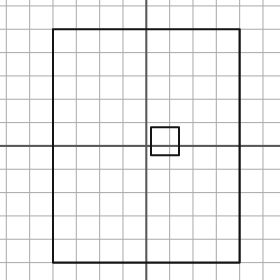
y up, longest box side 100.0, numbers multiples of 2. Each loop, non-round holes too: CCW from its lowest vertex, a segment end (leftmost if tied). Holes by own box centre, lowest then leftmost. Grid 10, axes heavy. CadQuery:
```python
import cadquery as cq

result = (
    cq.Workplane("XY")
    .moveTo(-40.0, -50.0)
    .lineTo(40.0, -50.0)
    .lineTo(40.0, 50.0)
    .lineTo(-40.0, 50.0)
    .close()
    .moveTo(2.0, -4.0)
    .lineTo(14.0, -4.0)
    .lineTo(14.0, 8.0)
    .lineTo(2.0, 8.0)
    .close()
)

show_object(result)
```